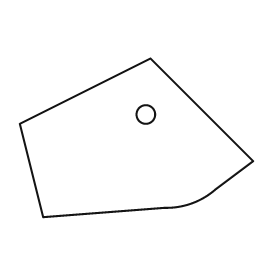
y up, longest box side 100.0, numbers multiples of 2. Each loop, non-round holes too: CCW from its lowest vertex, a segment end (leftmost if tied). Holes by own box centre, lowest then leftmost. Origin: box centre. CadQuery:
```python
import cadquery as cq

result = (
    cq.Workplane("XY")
    .moveTo(-40.0, -34.0)
    .lineTo(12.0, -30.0)
    .threePointArc((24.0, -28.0), (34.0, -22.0))
    .lineTo(50.0, -10.0)
    .lineTo(6.0, 34.0)
    .lineTo(-50.0, 6.0)
    .close()
    .moveTo(4.0, 10.0)
    .circle(4.0)
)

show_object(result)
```